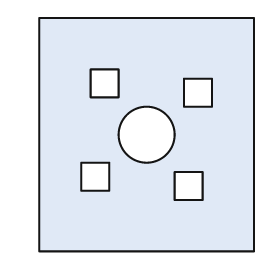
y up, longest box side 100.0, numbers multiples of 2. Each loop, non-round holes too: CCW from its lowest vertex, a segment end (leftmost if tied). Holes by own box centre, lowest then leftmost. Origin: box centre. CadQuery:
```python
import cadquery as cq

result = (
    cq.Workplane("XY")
    .moveTo(-46.0, -50.0)
    .lineTo(46.0, -50.0)
    .lineTo(46.0, 50.0)
    .lineTo(-46.0, 50.0)
    .close()
    .moveTo(12.0, -28.0)
    .lineTo(24.0, -28.0)
    .lineTo(24.0, -16.0)
    .lineTo(12.0, -16.0)
    .close()
    .moveTo(-28.0, -24.0)
    .lineTo(-16.0, -24.0)
    .lineTo(-16.0, -12.0)
    .lineTo(-28.0, -12.0)
    .close()
    .moveTo(0.0, 0.0)
    .circle(12.0)
    .moveTo(16.0, 12.0)
    .lineTo(28.0, 12.0)
    .lineTo(28.0, 24.0)
    .lineTo(16.0, 24.0)
    .close()
    .moveTo(-24.0, 16.0)
    .lineTo(-12.0, 16.0)
    .lineTo(-12.0, 28.0)
    .lineTo(-24.0, 28.0)
    .close()
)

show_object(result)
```